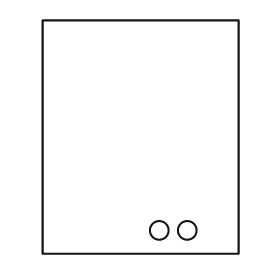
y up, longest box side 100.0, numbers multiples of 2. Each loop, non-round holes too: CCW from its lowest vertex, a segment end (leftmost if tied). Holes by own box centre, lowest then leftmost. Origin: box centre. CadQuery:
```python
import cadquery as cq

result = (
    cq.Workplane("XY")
    .moveTo(-42.0, -50.0)
    .lineTo(42.0, -50.0)
    .lineTo(42.0, 50.0)
    .lineTo(-42.0, 50.0)
    .close()
    .moveTo(8.0, -40.0)
    .circle(4.0)
    .moveTo(20.0, -40.0)
    .circle(4.0)
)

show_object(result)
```